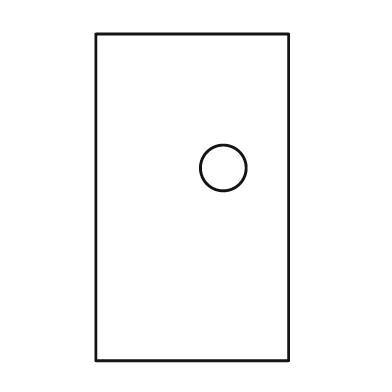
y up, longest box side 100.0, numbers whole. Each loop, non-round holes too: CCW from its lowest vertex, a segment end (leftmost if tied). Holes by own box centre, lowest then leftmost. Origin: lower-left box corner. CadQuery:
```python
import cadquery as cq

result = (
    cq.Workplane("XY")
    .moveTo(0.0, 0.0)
    .lineTo(59.0, 0.0)
    .lineTo(59.0, 100.0)
    .lineTo(0.0, 100.0)
    .close()
    .moveTo(39.0, 59.0)
    .circle(7.0)
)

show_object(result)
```